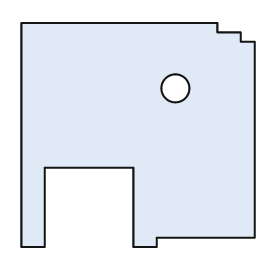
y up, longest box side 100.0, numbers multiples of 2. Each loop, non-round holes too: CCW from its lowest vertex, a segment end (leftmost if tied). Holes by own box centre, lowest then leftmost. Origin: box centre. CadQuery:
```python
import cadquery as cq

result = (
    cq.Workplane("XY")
    .moveTo(-50.0, -48.0)
    .lineTo(-40.0, -48.0)
    .lineTo(-40.0, -14.0)
    .lineTo(-2.0, -14.0)
    .lineTo(-2.0, -48.0)
    .lineTo(8.0, -48.0)
    .lineTo(8.0, -44.0)
    .lineTo(50.0, -44.0)
    .lineTo(50.0, 40.0)
    .lineTo(44.0, 40.0)
    .lineTo(44.0, 44.0)
    .lineTo(34.0, 44.0)
    .lineTo(34.0, 48.0)
    .lineTo(-50.0, 48.0)
    .close()
    .moveTo(16.0, 20.0)
    .circle(6.0)
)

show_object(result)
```